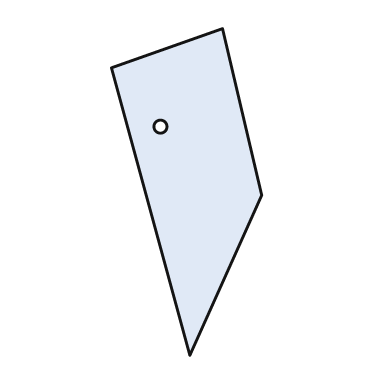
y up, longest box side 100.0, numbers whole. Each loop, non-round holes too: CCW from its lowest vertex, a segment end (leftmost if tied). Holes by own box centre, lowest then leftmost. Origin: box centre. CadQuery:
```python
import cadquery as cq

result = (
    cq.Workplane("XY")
    .moveTo(1.0, -50.0)
    .lineTo(23.0, -1.0)
    .lineTo(11.0, 50.0)
    .lineTo(-23.0, 38.0)
    .close()
    .moveTo(-8.0, 20.0)
    .circle(2.0)
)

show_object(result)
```